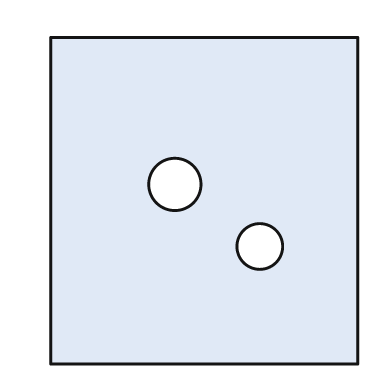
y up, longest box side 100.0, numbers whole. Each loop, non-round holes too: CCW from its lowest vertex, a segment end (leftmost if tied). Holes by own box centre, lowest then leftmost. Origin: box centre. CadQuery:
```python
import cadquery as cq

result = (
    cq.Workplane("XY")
    .moveTo(-47.0, -50.0)
    .lineTo(47.0, -50.0)
    .lineTo(47.0, 50.0)
    .lineTo(-47.0, 50.0)
    .close()
    .moveTo(17.0, -14.0)
    .circle(7.0)
    .moveTo(-9.0, 5.0)
    .circle(8.0)
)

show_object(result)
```